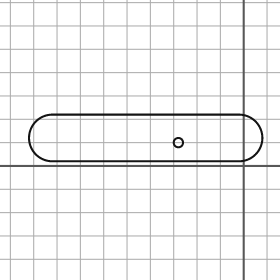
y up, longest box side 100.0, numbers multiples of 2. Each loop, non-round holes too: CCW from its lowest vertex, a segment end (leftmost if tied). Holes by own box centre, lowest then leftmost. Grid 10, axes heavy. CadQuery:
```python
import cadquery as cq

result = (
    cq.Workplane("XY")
    .moveTo(-82.0, 2.0)
    .lineTo(-2.0, 2.0)
    .threePointArc((8.0, 12.0), (-2.0, 22.0))
    .lineTo(-82.0, 22.0)
    .threePointArc((-92.0, 12.0), (-82.0, 2.0))
    .close()
    .moveTo(-28.0, 10.0)
    .circle(2.0)
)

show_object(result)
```